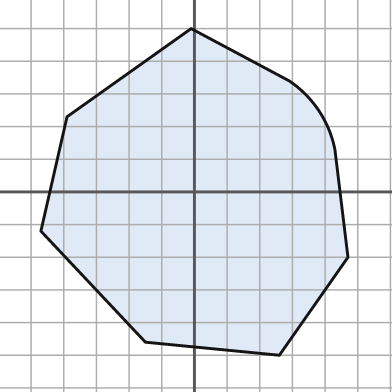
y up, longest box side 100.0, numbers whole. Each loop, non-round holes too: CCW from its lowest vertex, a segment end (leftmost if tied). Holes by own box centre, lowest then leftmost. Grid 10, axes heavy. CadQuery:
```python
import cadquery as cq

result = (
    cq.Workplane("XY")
    .moveTo(26.0, -50.0)
    .lineTo(47.0, -20.0)
    .lineTo(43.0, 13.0)
    .threePointArc((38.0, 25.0), (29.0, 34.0))
    .lineTo(-1.0, 50.0)
    .lineTo(-39.0, 23.0)
    .lineTo(-47.0, -12.0)
    .lineTo(-15.0, -46.0)
    .close()
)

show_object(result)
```